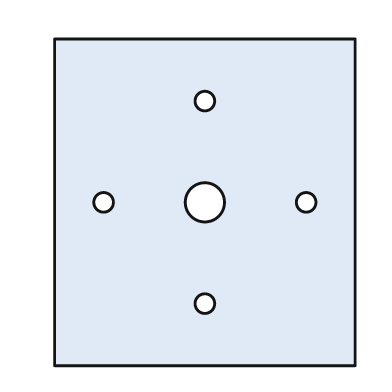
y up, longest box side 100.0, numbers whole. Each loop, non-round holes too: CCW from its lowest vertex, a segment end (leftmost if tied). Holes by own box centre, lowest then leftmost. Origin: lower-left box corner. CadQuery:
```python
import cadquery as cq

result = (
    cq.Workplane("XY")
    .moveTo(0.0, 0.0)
    .lineTo(92.0, 0.0)
    .lineTo(92.0, 100.0)
    .lineTo(0.0, 100.0)
    .close()
    .moveTo(46.0, 19.0)
    .circle(3.0)
    .moveTo(15.0, 50.0)
    .circle(3.0)
    .moveTo(46.0, 50.0)
    .circle(6.0)
    .moveTo(77.0, 50.0)
    .circle(3.0)
    .moveTo(46.0, 81.0)
    .circle(3.0)
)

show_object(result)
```